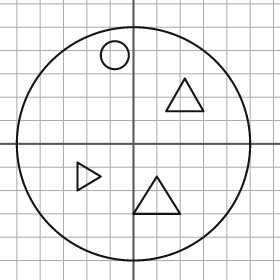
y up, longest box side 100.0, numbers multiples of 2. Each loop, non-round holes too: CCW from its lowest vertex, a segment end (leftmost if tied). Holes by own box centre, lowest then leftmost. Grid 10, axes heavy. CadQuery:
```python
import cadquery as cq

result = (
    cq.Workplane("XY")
    .moveTo(0.0, 0.0)
    .circle(50.0)
    .moveTo(0.0, -30.0)
    .lineTo(20.0, -30.0)
    .lineTo(10.0, -14.0)
    .close()
    .moveTo(-24.0, -20.0)
    .lineTo(-14.0, -14.0)
    .lineTo(-24.0, -8.0)
    .close()
    .moveTo(14.0, 14.0)
    .lineTo(30.0, 14.0)
    .lineTo(22.0, 28.0)
    .close()
    .moveTo(-8.0, 38.0)
    .circle(6.0)
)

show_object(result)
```